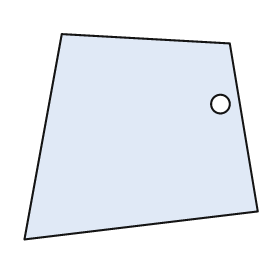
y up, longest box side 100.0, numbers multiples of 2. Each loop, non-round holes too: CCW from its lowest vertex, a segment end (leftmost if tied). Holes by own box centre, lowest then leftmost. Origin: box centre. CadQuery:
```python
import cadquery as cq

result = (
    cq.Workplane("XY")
    .moveTo(-50.0, -44.0)
    .lineTo(50.0, -32.0)
    .lineTo(38.0, 40.0)
    .lineTo(-34.0, 44.0)
    .close()
    .moveTo(34.0, 14.0)
    .circle(4.0)
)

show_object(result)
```